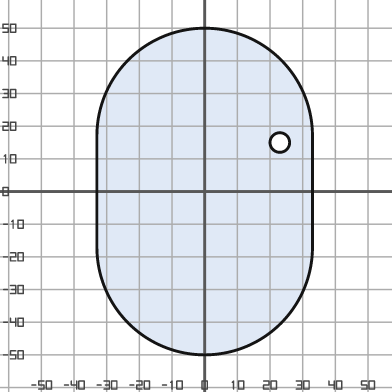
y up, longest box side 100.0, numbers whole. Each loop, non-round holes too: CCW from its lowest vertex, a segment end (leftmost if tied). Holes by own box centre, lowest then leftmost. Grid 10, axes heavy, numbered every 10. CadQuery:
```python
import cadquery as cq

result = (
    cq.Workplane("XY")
    .moveTo(-33.0, -17.0)
    .threePointArc((0.0, -50.0), (33.0, -17.0))
    .lineTo(33.0, 17.0)
    .threePointArc((0.0, 50.0), (-33.0, 17.0))
    .close()
    .moveTo(23.0, 15.0)
    .circle(3.0)
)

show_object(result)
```